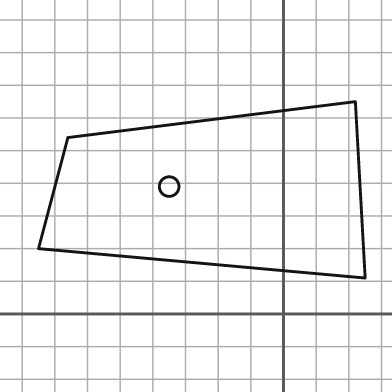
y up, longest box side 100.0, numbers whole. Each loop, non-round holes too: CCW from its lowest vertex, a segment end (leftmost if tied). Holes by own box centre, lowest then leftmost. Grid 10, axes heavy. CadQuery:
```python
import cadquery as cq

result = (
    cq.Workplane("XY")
    .moveTo(25.0, 11.0)
    .lineTo(22.0, 65.0)
    .lineTo(-66.0, 54.0)
    .lineTo(-75.0, 20.0)
    .close()
    .moveTo(-35.0, 39.0)
    .circle(3.0)
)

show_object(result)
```